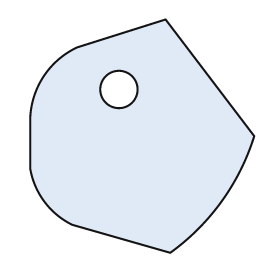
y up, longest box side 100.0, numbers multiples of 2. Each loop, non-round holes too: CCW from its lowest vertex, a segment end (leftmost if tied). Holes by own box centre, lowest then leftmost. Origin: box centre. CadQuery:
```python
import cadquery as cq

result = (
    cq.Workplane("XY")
    .moveTo(12.0, -50.0)
    .threePointArc((34.0, -28.0), (48.0, 0.0))
    .lineTo(10.0, 50.0)
    .lineTo(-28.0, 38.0)
    .threePointArc((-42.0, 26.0), (-48.0, 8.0))
    .lineTo(-48.0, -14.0)
    .threePointArc((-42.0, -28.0), (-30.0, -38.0))
    .close()
    .moveTo(-10.0, 20.0)
    .circle(8.0)
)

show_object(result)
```